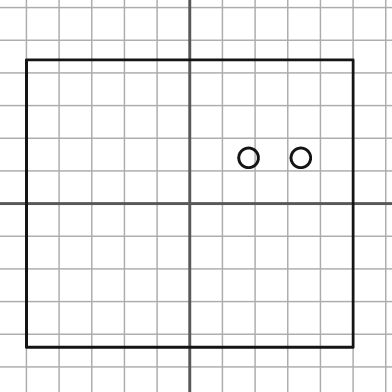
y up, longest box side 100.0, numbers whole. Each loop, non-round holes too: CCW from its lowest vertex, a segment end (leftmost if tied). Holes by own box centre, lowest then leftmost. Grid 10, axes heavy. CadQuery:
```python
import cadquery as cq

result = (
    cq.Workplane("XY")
    .moveTo(-50.0, -44.0)
    .lineTo(50.0, -44.0)
    .lineTo(50.0, 44.0)
    .lineTo(-50.0, 44.0)
    .close()
    .moveTo(18.0, 14.0)
    .circle(3.0)
    .moveTo(34.0, 14.0)
    .circle(3.0)
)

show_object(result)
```